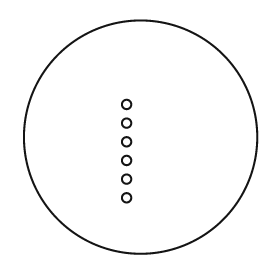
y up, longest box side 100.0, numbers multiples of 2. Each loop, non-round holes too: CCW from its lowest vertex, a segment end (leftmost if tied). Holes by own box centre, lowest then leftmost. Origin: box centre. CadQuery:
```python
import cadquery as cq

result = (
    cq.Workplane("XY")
    .moveTo(0.0, 0.0)
    .circle(50.0)
    .moveTo(-6.0, -26.0)
    .circle(2.0)
    .moveTo(-6.0, -18.0)
    .circle(2.0)
    .moveTo(-6.0, -10.0)
    .circle(2.0)
    .moveTo(-6.0, -2.0)
    .circle(2.0)
    .moveTo(-6.0, 6.0)
    .circle(2.0)
    .moveTo(-6.0, 14.0)
    .circle(2.0)
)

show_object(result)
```